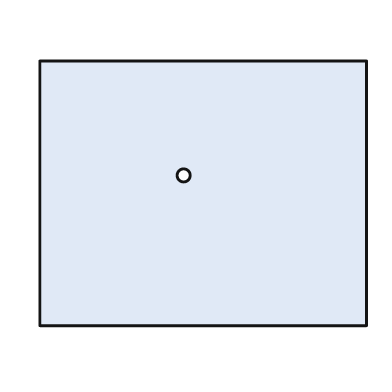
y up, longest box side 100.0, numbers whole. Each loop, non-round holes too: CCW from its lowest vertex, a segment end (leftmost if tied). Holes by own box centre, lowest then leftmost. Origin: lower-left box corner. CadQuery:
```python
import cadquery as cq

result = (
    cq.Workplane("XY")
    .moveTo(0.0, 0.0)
    .lineTo(100.0, 0.0)
    .lineTo(100.0, 81.0)
    .lineTo(0.0, 81.0)
    .close()
    .moveTo(44.0, 46.0)
    .circle(2.0)
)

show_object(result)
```